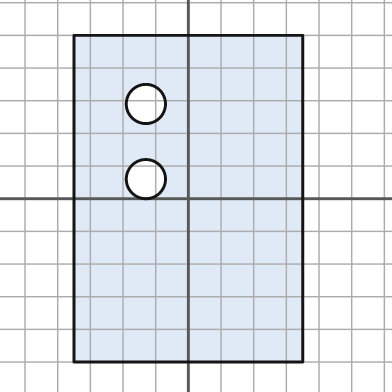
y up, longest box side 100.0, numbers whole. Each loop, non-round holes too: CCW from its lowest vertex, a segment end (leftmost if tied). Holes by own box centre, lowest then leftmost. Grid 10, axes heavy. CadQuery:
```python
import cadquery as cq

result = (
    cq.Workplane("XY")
    .moveTo(-35.0, -50.0)
    .lineTo(35.0, -50.0)
    .lineTo(35.0, 50.0)
    .lineTo(-35.0, 50.0)
    .close()
    .moveTo(-13.0, 6.0)
    .circle(6.0)
    .moveTo(-13.0, 29.0)
    .circle(6.0)
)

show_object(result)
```